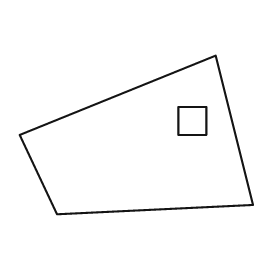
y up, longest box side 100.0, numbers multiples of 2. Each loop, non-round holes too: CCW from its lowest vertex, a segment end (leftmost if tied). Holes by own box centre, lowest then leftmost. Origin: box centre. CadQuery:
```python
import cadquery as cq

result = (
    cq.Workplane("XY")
    .moveTo(-34.0, -34.0)
    .lineTo(50.0, -30.0)
    .lineTo(34.0, 34.0)
    .lineTo(-50.0, 0.0)
    .close()
    .moveTo(18.0, 0.0)
    .lineTo(30.0, 0.0)
    .lineTo(30.0, 12.0)
    .lineTo(18.0, 12.0)
    .close()
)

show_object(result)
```